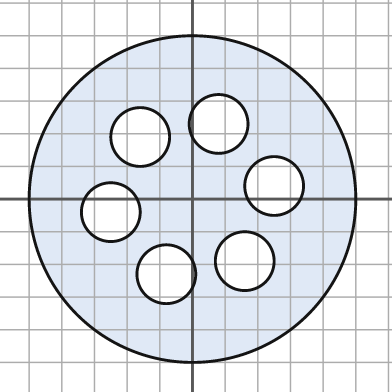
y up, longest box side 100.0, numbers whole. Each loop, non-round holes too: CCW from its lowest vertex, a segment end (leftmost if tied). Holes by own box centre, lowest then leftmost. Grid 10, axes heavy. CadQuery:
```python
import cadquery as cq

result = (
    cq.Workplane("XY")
    .moveTo(0.0, 0.0)
    .circle(50.0)
    .moveTo(-8.0, -23.0)
    .circle(9.0)
    .moveTo(16.0, -19.0)
    .circle(9.0)
    .moveTo(-25.0, -4.0)
    .circle(9.0)
    .moveTo(25.0, 4.0)
    .circle(9.0)
    .moveTo(-16.0, 19.0)
    .circle(9.0)
    .moveTo(8.0, 23.0)
    .circle(9.0)
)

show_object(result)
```